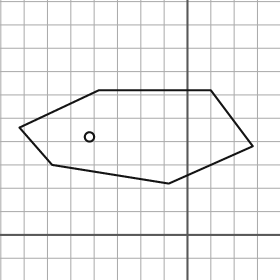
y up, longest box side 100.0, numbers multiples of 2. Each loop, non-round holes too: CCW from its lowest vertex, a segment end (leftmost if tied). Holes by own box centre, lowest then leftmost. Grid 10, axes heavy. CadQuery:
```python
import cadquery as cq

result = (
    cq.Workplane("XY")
    .moveTo(-8.0, 22.0)
    .lineTo(28.0, 38.0)
    .lineTo(10.0, 62.0)
    .lineTo(-38.0, 62.0)
    .lineTo(-72.0, 46.0)
    .lineTo(-58.0, 30.0)
    .close()
    .moveTo(-42.0, 42.0)
    .circle(2.0)
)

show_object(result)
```